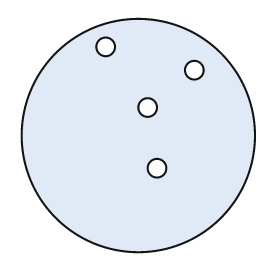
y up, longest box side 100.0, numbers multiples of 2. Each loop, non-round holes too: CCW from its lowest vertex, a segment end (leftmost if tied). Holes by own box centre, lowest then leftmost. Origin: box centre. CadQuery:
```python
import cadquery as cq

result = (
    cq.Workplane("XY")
    .moveTo(0.0, 0.0)
    .circle(50.0)
    .moveTo(8.0, -14.0)
    .circle(4.0)
    .moveTo(4.0, 12.0)
    .circle(4.0)
    .moveTo(24.0, 28.0)
    .circle(4.0)
    .moveTo(-14.0, 38.0)
    .circle(4.0)
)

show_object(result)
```